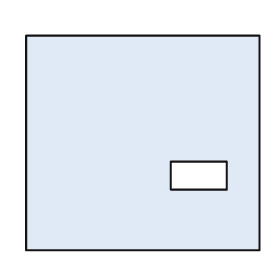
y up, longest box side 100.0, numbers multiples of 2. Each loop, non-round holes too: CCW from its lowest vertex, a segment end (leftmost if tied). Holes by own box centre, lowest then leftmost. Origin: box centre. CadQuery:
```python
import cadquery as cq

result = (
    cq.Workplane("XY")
    .moveTo(-50.0, -46.0)
    .lineTo(50.0, -46.0)
    .lineTo(50.0, 46.0)
    .lineTo(-50.0, 46.0)
    .close()
    .moveTo(12.0, -20.0)
    .lineTo(36.0, -20.0)
    .lineTo(36.0, -8.0)
    .lineTo(12.0, -8.0)
    .close()
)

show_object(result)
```